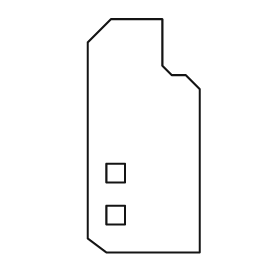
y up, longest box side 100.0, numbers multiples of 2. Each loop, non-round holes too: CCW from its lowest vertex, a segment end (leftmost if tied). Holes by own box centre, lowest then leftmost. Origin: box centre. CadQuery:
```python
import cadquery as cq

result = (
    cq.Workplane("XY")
    .moveTo(-16.0, -50.0)
    .lineTo(24.0, -50.0)
    .lineTo(24.0, 20.0)
    .lineTo(18.0, 26.0)
    .lineTo(12.0, 26.0)
    .lineTo(8.0, 30.0)
    .lineTo(8.0, 50.0)
    .lineTo(-14.0, 50.0)
    .lineTo(-24.0, 40.0)
    .lineTo(-24.0, -44.0)
    .close()
    .moveTo(-16.0, -38.0)
    .lineTo(-8.0, -38.0)
    .lineTo(-8.0, -30.0)
    .lineTo(-16.0, -30.0)
    .close()
    .moveTo(-16.0, -20.0)
    .lineTo(-8.0, -20.0)
    .lineTo(-8.0, -12.0)
    .lineTo(-16.0, -12.0)
    .close()
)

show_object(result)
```